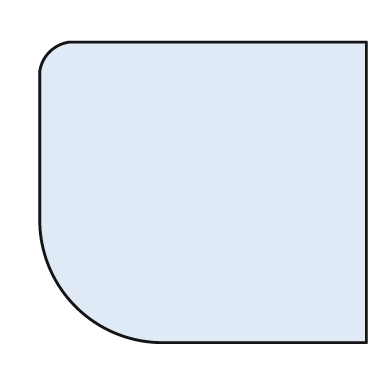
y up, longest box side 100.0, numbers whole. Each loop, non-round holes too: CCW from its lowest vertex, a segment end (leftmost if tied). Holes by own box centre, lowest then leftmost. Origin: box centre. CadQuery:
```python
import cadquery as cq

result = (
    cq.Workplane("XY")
    .moveTo(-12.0, -46.0)
    .lineTo(50.0, -46.0)
    .lineTo(50.0, 46.0)
    .lineTo(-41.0, 46.0)
    .threePointArc((-47.0, 43.0), (-50.0, 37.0))
    .lineTo(-50.0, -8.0)
    .threePointArc((-39.0, -35.0), (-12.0, -46.0))
    .close()
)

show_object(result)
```